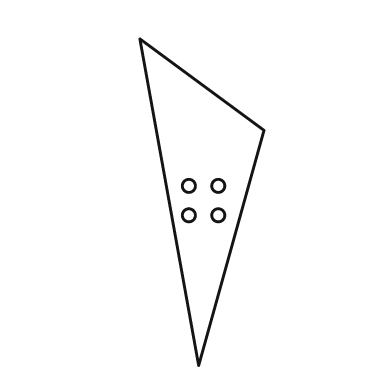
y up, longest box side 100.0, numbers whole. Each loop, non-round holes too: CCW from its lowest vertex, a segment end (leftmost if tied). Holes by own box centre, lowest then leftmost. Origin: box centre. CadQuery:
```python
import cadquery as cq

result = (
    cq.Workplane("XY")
    .moveTo(-1.0, -50.0)
    .lineTo(19.0, 22.0)
    .lineTo(-19.0, 50.0)
    .close()
    .moveTo(-4.0, -4.0)
    .circle(2.0)
    .moveTo(5.0, -4.0)
    .circle(2.0)
    .moveTo(-4.0, 5.0)
    .circle(2.0)
    .moveTo(5.0, 5.0)
    .circle(2.0)
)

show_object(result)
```